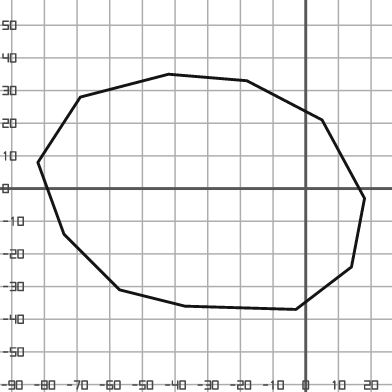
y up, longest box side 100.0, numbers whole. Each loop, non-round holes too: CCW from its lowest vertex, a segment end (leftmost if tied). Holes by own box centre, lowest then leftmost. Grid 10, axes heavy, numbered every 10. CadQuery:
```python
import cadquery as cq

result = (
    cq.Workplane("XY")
    .moveTo(-3.0, -37.0)
    .lineTo(14.0, -24.0)
    .lineTo(18.0, -3.0)
    .lineTo(5.0, 21.0)
    .lineTo(-18.0, 33.0)
    .lineTo(-42.0, 35.0)
    .lineTo(-69.0, 28.0)
    .lineTo(-82.0, 8.0)
    .lineTo(-74.0, -14.0)
    .lineTo(-57.0, -31.0)
    .lineTo(-37.0, -36.0)
    .close()
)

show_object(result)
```